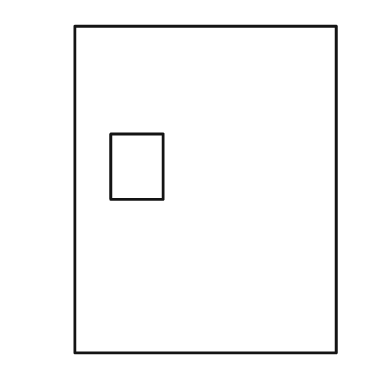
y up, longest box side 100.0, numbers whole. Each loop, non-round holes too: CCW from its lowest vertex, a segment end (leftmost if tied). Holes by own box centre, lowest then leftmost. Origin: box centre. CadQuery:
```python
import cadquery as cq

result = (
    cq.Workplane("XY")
    .moveTo(-40.0, -50.0)
    .lineTo(40.0, -50.0)
    .lineTo(40.0, 50.0)
    .lineTo(-40.0, 50.0)
    .close()
    .moveTo(-29.0, -3.0)
    .lineTo(-13.0, -3.0)
    .lineTo(-13.0, 17.0)
    .lineTo(-29.0, 17.0)
    .close()
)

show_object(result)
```